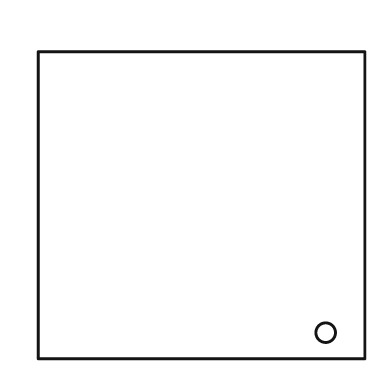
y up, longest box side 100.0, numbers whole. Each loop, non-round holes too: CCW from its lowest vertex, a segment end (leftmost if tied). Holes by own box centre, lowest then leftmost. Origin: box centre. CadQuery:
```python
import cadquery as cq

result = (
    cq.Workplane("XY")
    .moveTo(-50.0, -47.0)
    .lineTo(50.0, -47.0)
    .lineTo(50.0, 47.0)
    .lineTo(-50.0, 47.0)
    .close()
    .moveTo(38.0, -39.0)
    .circle(3.0)
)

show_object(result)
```